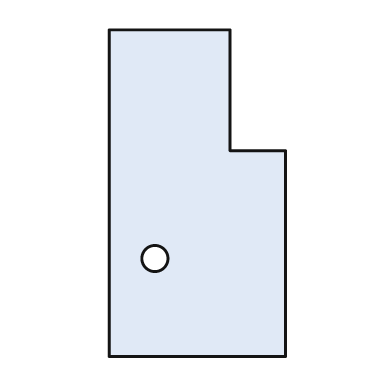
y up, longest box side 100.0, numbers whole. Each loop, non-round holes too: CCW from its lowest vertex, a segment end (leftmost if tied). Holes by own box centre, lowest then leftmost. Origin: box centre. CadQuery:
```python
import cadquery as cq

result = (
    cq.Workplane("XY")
    .moveTo(-27.0, -50.0)
    .lineTo(27.0, -50.0)
    .lineTo(27.0, 13.0)
    .lineTo(10.0, 13.0)
    .lineTo(10.0, 50.0)
    .lineTo(-27.0, 50.0)
    .close()
    .moveTo(-13.0, -20.0)
    .circle(4.0)
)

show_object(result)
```